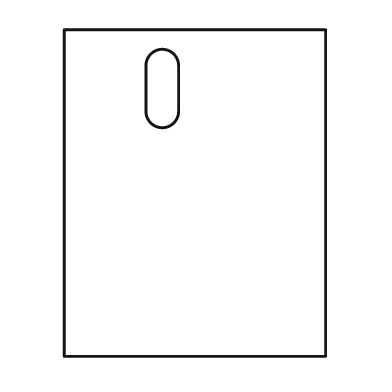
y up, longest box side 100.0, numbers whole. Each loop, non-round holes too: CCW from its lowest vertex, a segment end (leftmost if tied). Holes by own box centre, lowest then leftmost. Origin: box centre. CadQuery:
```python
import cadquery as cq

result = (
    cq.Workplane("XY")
    .moveTo(-40.0, -50.0)
    .lineTo(40.0, -50.0)
    .lineTo(40.0, 50.0)
    .lineTo(-40.0, 50.0)
    .close()
    .moveTo(-15.0, 25.0)
    .threePointArc((-10.0, 20.0), (-5.0, 25.0))
    .lineTo(-5.0, 39.0)
    .threePointArc((-10.0, 44.0), (-15.0, 39.0))
    .close()
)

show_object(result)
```